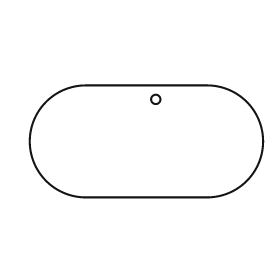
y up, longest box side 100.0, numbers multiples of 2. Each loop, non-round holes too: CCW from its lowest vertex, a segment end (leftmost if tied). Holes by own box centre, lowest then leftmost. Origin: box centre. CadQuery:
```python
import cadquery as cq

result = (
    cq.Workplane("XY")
    .moveTo(-26.0, -24.0)
    .lineTo(26.0, -24.0)
    .threePointArc((50.0, 0.0), (26.0, 24.0))
    .lineTo(-26.0, 24.0)
    .threePointArc((-50.0, 0.0), (-26.0, -24.0))
    .close()
    .moveTo(4.0, 18.0)
    .circle(2.0)
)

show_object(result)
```